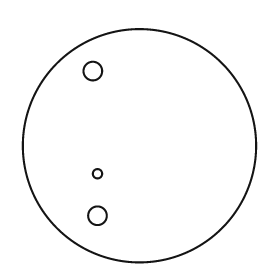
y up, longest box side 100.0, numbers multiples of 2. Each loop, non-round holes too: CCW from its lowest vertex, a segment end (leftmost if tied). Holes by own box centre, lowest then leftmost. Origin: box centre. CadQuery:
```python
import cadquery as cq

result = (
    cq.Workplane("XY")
    .moveTo(0.0, 0.0)
    .circle(50.0)
    .moveTo(-18.0, -30.0)
    .circle(4.0)
    .moveTo(-18.0, -12.0)
    .circle(2.0)
    .moveTo(-20.0, 32.0)
    .circle(4.0)
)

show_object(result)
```